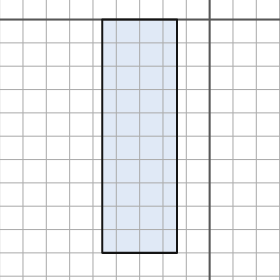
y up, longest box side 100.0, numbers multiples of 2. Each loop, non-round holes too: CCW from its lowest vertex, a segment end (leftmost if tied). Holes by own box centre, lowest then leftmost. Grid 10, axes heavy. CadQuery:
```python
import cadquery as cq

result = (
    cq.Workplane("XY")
    .moveTo(-46.0, -100.0)
    .lineTo(-14.0, -100.0)
    .lineTo(-14.0, 0.0)
    .lineTo(-46.0, 0.0)
    .close()
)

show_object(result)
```